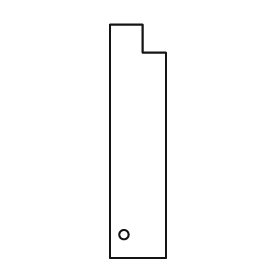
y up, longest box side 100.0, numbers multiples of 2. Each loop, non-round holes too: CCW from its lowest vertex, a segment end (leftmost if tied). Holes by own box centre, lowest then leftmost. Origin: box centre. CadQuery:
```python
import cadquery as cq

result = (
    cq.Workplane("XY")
    .moveTo(-12.0, -50.0)
    .lineTo(12.0, -50.0)
    .lineTo(12.0, 38.0)
    .lineTo(2.0, 38.0)
    .lineTo(2.0, 50.0)
    .lineTo(-12.0, 50.0)
    .close()
    .moveTo(-6.0, -40.0)
    .circle(2.0)
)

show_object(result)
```